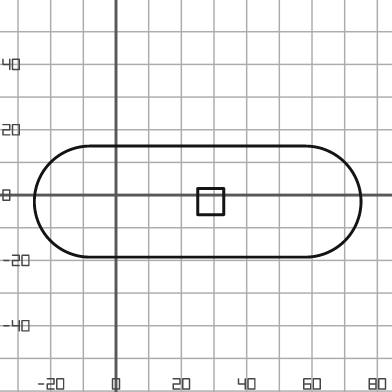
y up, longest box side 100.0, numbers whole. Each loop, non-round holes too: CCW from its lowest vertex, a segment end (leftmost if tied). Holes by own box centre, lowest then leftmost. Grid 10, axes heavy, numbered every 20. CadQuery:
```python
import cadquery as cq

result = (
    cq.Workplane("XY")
    .moveTo(-8.0, -19.0)
    .lineTo(58.0, -19.0)
    .threePointArc((75.0, -2.0), (58.0, 15.0))
    .lineTo(-8.0, 15.0)
    .threePointArc((-25.0, -2.0), (-8.0, -19.0))
    .close()
    .moveTo(25.0, -6.0)
    .lineTo(33.0, -6.0)
    .lineTo(33.0, 2.0)
    .lineTo(25.0, 2.0)
    .close()
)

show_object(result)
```